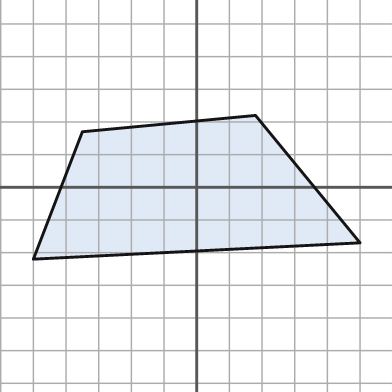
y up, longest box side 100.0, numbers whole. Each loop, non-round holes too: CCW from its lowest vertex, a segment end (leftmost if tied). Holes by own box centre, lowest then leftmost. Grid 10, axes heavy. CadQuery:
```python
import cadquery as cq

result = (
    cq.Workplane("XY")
    .moveTo(-50.0, -22.0)
    .lineTo(50.0, -17.0)
    .lineTo(18.0, 22.0)
    .lineTo(-35.0, 17.0)
    .close()
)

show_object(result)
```